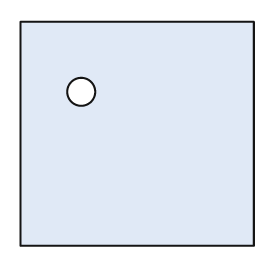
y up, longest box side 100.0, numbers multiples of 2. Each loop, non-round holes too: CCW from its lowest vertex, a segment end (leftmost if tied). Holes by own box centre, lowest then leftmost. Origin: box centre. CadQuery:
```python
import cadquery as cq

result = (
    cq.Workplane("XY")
    .moveTo(-50.0, -48.0)
    .lineTo(50.0, -48.0)
    .lineTo(50.0, 48.0)
    .lineTo(-50.0, 48.0)
    .close()
    .moveTo(-24.0, 18.0)
    .circle(6.0)
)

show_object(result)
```